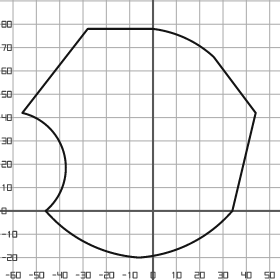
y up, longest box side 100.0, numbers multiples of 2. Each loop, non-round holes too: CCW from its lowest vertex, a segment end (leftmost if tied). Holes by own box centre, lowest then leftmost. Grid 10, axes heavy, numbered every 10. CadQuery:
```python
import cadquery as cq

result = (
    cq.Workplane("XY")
    .moveTo(-6.0, -20.0)
    .threePointArc((16.0, -14.0), (34.0, 0.0))
    .lineTo(44.0, 42.0)
    .lineTo(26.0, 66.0)
    .threePointArc((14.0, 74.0), (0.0, 78.0))
    .lineTo(-28.0, 78.0)
    .lineTo(-56.0, 42.0)
    .threePointArc((-38.0, 24.0), (-46.0, 0.0))
    .threePointArc((-28.0, -14.0), (-6.0, -20.0))
    .close()
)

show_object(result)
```